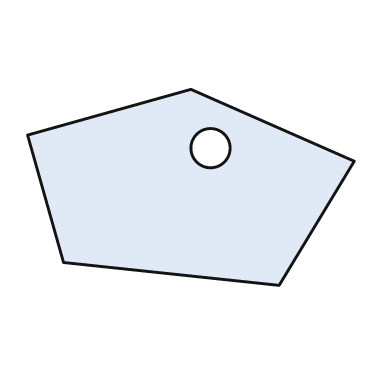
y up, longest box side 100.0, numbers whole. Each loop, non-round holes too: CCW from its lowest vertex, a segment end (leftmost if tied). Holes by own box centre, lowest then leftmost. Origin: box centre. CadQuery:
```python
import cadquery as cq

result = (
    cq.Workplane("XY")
    .moveTo(27.0, -30.0)
    .lineTo(50.0, 8.0)
    .lineTo(0.0, 30.0)
    .lineTo(-50.0, 16.0)
    .lineTo(-39.0, -23.0)
    .close()
    .moveTo(6.0, 12.0)
    .circle(6.0)
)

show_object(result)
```